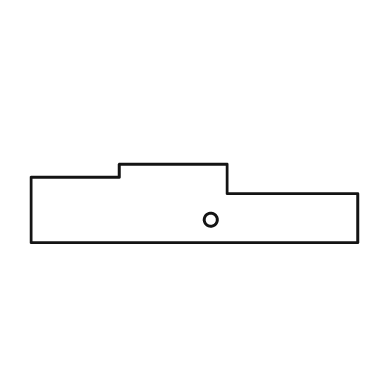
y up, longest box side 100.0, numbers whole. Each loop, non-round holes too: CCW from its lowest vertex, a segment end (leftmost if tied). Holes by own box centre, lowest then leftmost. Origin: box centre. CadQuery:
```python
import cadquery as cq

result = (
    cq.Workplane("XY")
    .moveTo(-50.0, -12.0)
    .lineTo(50.0, -12.0)
    .lineTo(50.0, 3.0)
    .lineTo(10.0, 3.0)
    .lineTo(10.0, 12.0)
    .lineTo(-23.0, 12.0)
    .lineTo(-23.0, 8.0)
    .lineTo(-50.0, 8.0)
    .close()
    .moveTo(5.0, -5.0)
    .circle(2.0)
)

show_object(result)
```